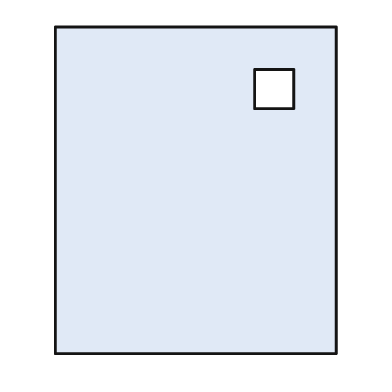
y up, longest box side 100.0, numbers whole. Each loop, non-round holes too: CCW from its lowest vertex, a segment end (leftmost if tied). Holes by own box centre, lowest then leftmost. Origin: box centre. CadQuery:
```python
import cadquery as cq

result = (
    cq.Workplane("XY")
    .moveTo(-43.0, -50.0)
    .lineTo(43.0, -50.0)
    .lineTo(43.0, 50.0)
    .lineTo(-43.0, 50.0)
    .close()
    .moveTo(18.0, 25.0)
    .lineTo(30.0, 25.0)
    .lineTo(30.0, 37.0)
    .lineTo(18.0, 37.0)
    .close()
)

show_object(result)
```